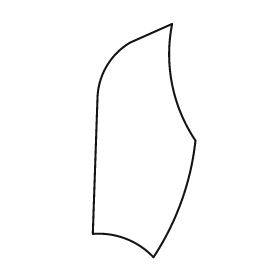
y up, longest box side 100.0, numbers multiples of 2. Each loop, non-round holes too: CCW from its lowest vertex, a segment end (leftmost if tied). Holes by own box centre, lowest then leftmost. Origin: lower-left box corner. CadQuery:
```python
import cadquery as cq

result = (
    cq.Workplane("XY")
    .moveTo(26.0, 0.0)
    .threePointArc((38.0, 24.0), (44.0, 50.0))
    .threePointArc((34.0, 74.0), (34.0, 100.0))
    .lineTo(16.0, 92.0)
    .threePointArc((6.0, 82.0), (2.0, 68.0))
    .lineTo(0.0, 10.0)
    .threePointArc((14.0, 8.0), (26.0, 0.0))
    .close()
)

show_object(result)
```